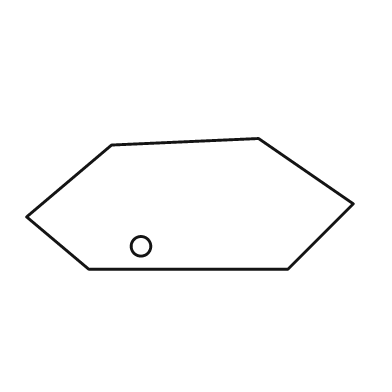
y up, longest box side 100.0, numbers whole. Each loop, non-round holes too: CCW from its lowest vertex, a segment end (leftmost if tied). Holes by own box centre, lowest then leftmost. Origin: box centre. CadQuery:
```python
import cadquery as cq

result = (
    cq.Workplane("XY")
    .moveTo(-31.0, -20.0)
    .lineTo(30.0, -20.0)
    .lineTo(50.0, 0.0)
    .lineTo(21.0, 20.0)
    .lineTo(-24.0, 18.0)
    .lineTo(-50.0, -4.0)
    .close()
    .moveTo(-15.0, -13.0)
    .circle(3.0)
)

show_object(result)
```